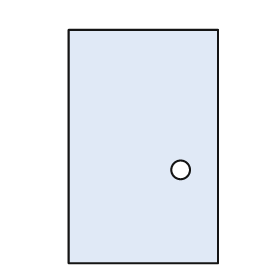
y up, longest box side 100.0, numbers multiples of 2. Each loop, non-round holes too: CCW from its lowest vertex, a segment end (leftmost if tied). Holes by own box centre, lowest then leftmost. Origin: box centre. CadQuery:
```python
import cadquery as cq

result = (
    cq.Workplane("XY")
    .moveTo(-32.0, -50.0)
    .lineTo(32.0, -50.0)
    .lineTo(32.0, 50.0)
    .lineTo(-32.0, 50.0)
    .close()
    .moveTo(16.0, -10.0)
    .circle(4.0)
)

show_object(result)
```